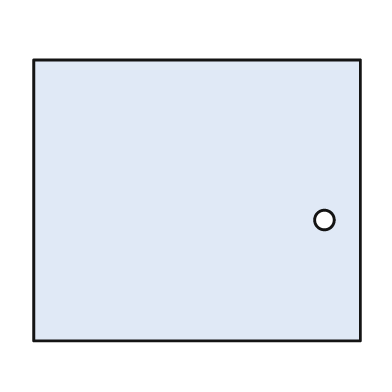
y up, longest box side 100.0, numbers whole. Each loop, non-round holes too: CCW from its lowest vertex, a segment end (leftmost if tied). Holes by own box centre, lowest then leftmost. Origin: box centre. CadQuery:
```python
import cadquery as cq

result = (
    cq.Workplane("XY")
    .moveTo(-50.0, -43.0)
    .lineTo(50.0, -43.0)
    .lineTo(50.0, 43.0)
    .lineTo(-50.0, 43.0)
    .close()
    .moveTo(39.0, -6.0)
    .circle(3.0)
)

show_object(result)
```